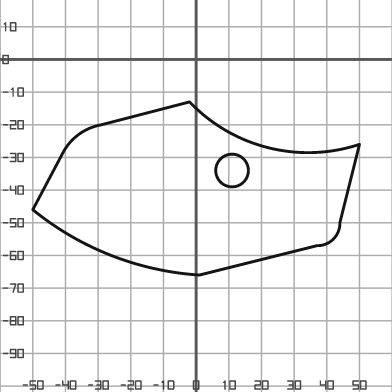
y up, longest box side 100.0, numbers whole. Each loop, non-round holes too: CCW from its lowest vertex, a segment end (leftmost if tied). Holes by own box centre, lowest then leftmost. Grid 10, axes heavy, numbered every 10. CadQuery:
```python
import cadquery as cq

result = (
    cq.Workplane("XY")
    .moveTo(1.0, -66.0)
    .lineTo(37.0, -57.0)
    .threePointArc((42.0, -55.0), (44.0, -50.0))
    .lineTo(50.0, -26.0)
    .threePointArc((22.0, -27.0), (-2.0, -13.0))
    .lineTo(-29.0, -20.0)
    .threePointArc((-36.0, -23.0), (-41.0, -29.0))
    .lineTo(-50.0, -46.0)
    .threePointArc((-26.0, -60.0), (1.0, -66.0))
    .close()
    .moveTo(11.0, -34.0)
    .circle(5.0)
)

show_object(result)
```